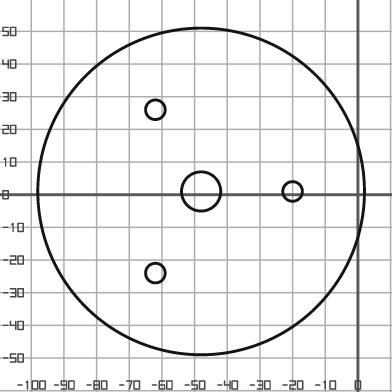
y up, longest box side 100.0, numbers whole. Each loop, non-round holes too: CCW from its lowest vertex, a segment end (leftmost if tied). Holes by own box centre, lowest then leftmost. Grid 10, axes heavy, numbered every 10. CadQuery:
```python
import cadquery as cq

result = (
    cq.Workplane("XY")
    .moveTo(-48.0, 1.0)
    .circle(50.0)
    .moveTo(-62.0, -24.0)
    .circle(3.0)
    .moveTo(-48.0, 1.0)
    .circle(6.0)
    .moveTo(-20.0, 1.0)
    .circle(3.0)
    .moveTo(-62.0, 26.0)
    .circle(3.0)
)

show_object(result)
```